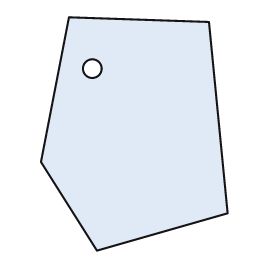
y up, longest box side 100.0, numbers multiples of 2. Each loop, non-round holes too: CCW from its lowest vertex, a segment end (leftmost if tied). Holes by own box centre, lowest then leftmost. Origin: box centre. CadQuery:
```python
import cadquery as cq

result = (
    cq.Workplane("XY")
    .moveTo(-16.0, -50.0)
    .lineTo(40.0, -34.0)
    .lineTo(32.0, 48.0)
    .lineTo(-28.0, 50.0)
    .lineTo(-40.0, -12.0)
    .close()
    .moveTo(-18.0, 28.0)
    .circle(4.0)
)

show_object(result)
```